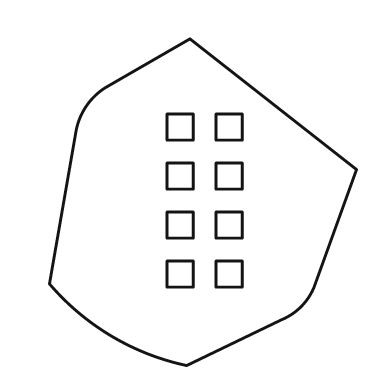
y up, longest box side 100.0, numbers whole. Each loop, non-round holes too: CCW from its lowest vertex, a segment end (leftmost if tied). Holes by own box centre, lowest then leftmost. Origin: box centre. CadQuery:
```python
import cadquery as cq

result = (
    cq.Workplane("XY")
    .moveTo(-5.0, -50.0)
    .lineTo(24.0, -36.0)
    .threePointArc((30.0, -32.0), (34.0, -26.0))
    .lineTo(47.0, 10.0)
    .lineTo(-4.0, 50.0)
    .lineTo(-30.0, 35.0)
    .threePointArc((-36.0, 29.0), (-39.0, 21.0))
    .lineTo(-47.0, -25.0)
    .threePointArc((-28.0, -41.0), (-5.0, -50.0))
    .close()
    .moveTo(-11.0, -26.0)
    .lineTo(-3.0, -26.0)
    .lineTo(-3.0, -18.0)
    .lineTo(-11.0, -18.0)
    .close()
    .moveTo(4.0, -26.0)
    .lineTo(12.0, -26.0)
    .lineTo(12.0, -18.0)
    .lineTo(4.0, -18.0)
    .close()
    .moveTo(-11.0, -11.0)
    .lineTo(-3.0, -11.0)
    .lineTo(-3.0, -3.0)
    .lineTo(-11.0, -3.0)
    .close()
    .moveTo(4.0, -11.0)
    .lineTo(12.0, -11.0)
    .lineTo(12.0, -3.0)
    .lineTo(4.0, -3.0)
    .close()
    .moveTo(-11.0, 4.0)
    .lineTo(-3.0, 4.0)
    .lineTo(-3.0, 12.0)
    .lineTo(-11.0, 12.0)
    .close()
    .moveTo(4.0, 4.0)
    .lineTo(12.0, 4.0)
    .lineTo(12.0, 12.0)
    .lineTo(4.0, 12.0)
    .close()
    .moveTo(-11.0, 19.0)
    .lineTo(-3.0, 19.0)
    .lineTo(-3.0, 27.0)
    .lineTo(-11.0, 27.0)
    .close()
    .moveTo(4.0, 19.0)
    .lineTo(12.0, 19.0)
    .lineTo(12.0, 27.0)
    .lineTo(4.0, 27.0)
    .close()
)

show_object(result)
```